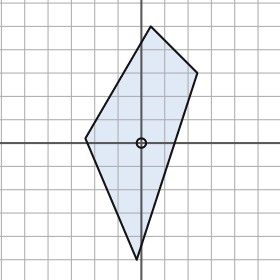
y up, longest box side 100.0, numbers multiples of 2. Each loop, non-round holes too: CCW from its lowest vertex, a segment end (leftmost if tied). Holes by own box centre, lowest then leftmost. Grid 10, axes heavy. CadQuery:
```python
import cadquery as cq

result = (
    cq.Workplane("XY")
    .moveTo(-2.0, -50.0)
    .lineTo(24.0, 30.0)
    .lineTo(4.0, 50.0)
    .lineTo(-24.0, 2.0)
    .close()
    .moveTo(0.0, 0.0)
    .circle(2.0)
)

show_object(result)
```